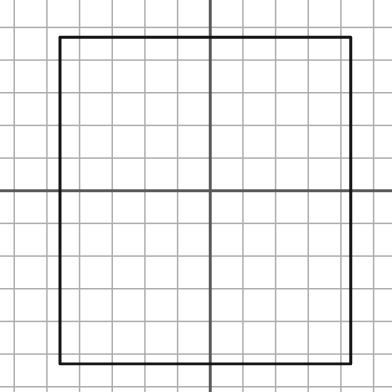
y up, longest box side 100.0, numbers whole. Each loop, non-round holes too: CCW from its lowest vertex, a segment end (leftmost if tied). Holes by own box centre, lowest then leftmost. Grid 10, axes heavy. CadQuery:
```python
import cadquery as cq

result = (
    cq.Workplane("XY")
    .moveTo(-46.0, -53.0)
    .lineTo(43.0, -53.0)
    .lineTo(43.0, 47.0)
    .lineTo(-46.0, 47.0)
    .close()
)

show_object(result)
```